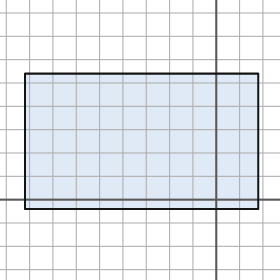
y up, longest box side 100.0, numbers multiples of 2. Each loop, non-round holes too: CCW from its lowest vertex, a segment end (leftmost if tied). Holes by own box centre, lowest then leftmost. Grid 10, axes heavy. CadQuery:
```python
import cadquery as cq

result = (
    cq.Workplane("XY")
    .moveTo(-82.0, -4.0)
    .lineTo(18.0, -4.0)
    .lineTo(18.0, 54.0)
    .lineTo(-82.0, 54.0)
    .close()
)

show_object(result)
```